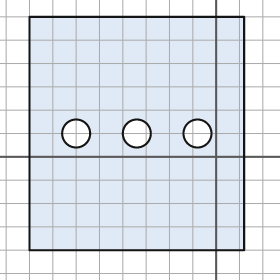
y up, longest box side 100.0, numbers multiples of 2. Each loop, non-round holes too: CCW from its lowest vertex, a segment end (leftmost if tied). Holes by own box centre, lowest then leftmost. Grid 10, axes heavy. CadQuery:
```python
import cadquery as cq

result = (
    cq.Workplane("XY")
    .moveTo(-80.0, -40.0)
    .lineTo(12.0, -40.0)
    .lineTo(12.0, 60.0)
    .lineTo(-80.0, 60.0)
    .close()
    .moveTo(-60.0, 10.0)
    .circle(6.0)
    .moveTo(-34.0, 10.0)
    .circle(6.0)
    .moveTo(-8.0, 10.0)
    .circle(6.0)
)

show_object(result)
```